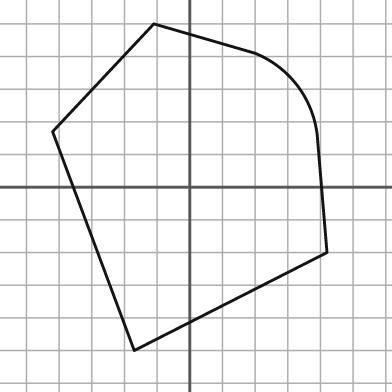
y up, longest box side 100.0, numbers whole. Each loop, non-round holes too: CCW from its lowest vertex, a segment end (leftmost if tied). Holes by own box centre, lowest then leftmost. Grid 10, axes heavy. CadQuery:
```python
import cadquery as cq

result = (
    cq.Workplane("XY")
    .moveTo(-17.0, -50.0)
    .lineTo(42.0, -20.0)
    .lineTo(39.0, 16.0)
    .threePointArc((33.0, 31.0), (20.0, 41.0))
    .lineTo(-11.0, 50.0)
    .lineTo(-42.0, 17.0)
    .close()
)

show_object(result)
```